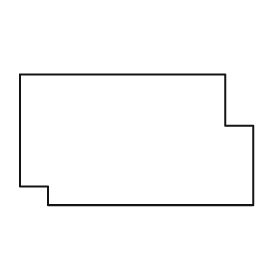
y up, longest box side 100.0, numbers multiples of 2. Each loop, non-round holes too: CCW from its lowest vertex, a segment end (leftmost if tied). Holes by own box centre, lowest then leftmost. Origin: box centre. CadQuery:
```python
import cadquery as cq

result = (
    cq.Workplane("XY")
    .moveTo(-38.0, -28.0)
    .lineTo(50.0, -28.0)
    .lineTo(50.0, 6.0)
    .lineTo(38.0, 6.0)
    .lineTo(38.0, 28.0)
    .lineTo(-50.0, 28.0)
    .lineTo(-50.0, -20.0)
    .lineTo(-38.0, -20.0)
    .close()
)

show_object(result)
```